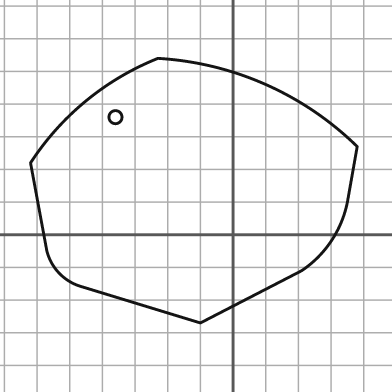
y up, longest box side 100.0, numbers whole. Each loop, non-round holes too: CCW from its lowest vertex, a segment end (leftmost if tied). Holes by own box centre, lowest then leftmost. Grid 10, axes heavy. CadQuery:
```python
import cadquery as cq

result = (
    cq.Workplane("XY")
    .moveTo(-10.0, -27.0)
    .lineTo(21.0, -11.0)
    .threePointArc((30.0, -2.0), (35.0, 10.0))
    .lineTo(38.0, 27.0)
    .threePointArc((10.0, 46.0), (-23.0, 54.0))
    .threePointArc((-45.0, 41.0), (-62.0, 22.0))
    .lineTo(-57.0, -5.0)
    .threePointArc((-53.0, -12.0), (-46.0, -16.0))
    .close()
    .moveTo(-36.0, 36.0)
    .circle(2.0)
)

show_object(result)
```